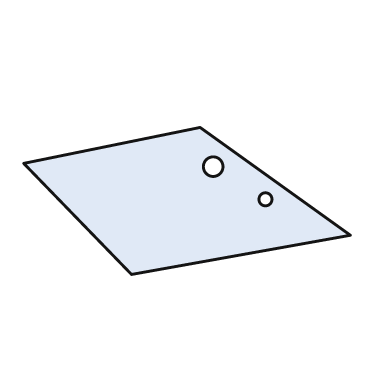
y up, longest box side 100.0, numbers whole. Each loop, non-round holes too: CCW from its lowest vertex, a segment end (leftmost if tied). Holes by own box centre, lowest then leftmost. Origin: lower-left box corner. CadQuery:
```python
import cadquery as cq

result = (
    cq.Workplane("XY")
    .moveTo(33.0, 0.0)
    .lineTo(100.0, 12.0)
    .lineTo(54.0, 45.0)
    .lineTo(0.0, 34.0)
    .close()
    .moveTo(74.0, 23.0)
    .circle(2.0)
    .moveTo(58.0, 33.0)
    .circle(3.0)
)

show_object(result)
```